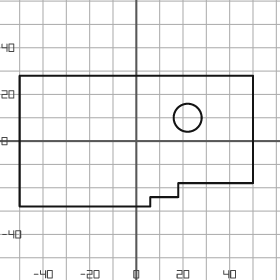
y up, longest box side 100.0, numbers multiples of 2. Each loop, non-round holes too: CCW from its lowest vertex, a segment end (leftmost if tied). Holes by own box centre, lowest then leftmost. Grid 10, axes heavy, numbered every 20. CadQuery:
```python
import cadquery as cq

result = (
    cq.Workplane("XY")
    .moveTo(-50.0, -28.0)
    .lineTo(6.0, -28.0)
    .lineTo(6.0, -24.0)
    .lineTo(18.0, -24.0)
    .lineTo(18.0, -18.0)
    .lineTo(50.0, -18.0)
    .lineTo(50.0, 28.0)
    .lineTo(-50.0, 28.0)
    .close()
    .moveTo(22.0, 10.0)
    .circle(6.0)
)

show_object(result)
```